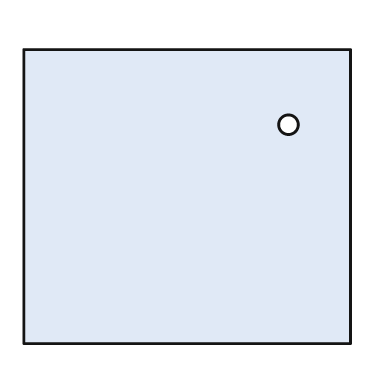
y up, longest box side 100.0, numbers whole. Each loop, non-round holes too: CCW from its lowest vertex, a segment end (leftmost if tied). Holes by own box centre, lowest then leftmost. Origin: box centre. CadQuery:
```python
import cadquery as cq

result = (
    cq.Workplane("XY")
    .moveTo(-50.0, -45.0)
    .lineTo(50.0, -45.0)
    .lineTo(50.0, 45.0)
    .lineTo(-50.0, 45.0)
    .close()
    .moveTo(31.0, 22.0)
    .circle(3.0)
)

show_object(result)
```